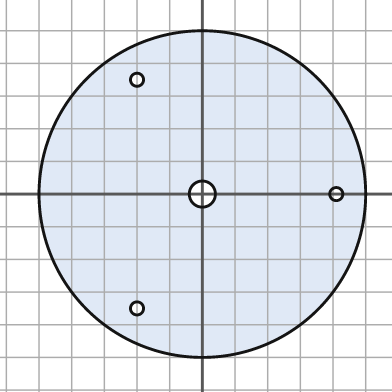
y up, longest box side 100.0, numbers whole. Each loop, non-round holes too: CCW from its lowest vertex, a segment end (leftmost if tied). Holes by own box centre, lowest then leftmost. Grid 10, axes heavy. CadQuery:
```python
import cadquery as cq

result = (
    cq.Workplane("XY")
    .moveTo(0.0, 0.0)
    .circle(50.0)
    .moveTo(-20.0, -35.0)
    .circle(2.0)
    .moveTo(0.0, 0.0)
    .circle(4.0)
    .moveTo(41.0, 0.0)
    .circle(2.0)
    .moveTo(-20.0, 35.0)
    .circle(2.0)
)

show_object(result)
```